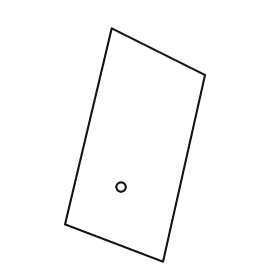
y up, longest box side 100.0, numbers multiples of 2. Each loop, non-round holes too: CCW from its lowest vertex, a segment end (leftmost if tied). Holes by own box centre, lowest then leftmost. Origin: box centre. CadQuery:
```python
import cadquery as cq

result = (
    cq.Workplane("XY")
    .moveTo(12.0, -50.0)
    .lineTo(30.0, 30.0)
    .lineTo(-10.0, 50.0)
    .lineTo(-30.0, -34.0)
    .close()
    .moveTo(-6.0, -18.0)
    .circle(2.0)
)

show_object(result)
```